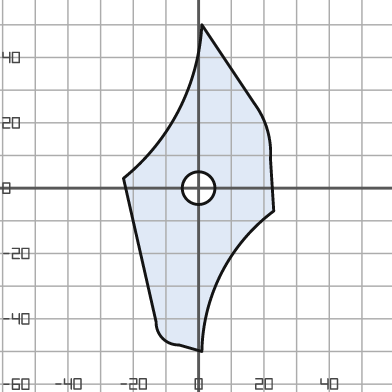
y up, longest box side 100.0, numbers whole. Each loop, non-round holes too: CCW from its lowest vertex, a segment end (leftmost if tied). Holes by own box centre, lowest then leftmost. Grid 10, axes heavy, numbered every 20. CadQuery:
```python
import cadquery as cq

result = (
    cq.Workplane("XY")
    .moveTo(1.0, -50.0)
    .threePointArc((7.0, -26.0), (23.0, -7.0))
    .lineTo(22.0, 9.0)
    .threePointArc((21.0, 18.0), (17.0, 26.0))
    .lineTo(1.0, 50.0)
    .threePointArc((-6.0, 24.0), (-23.0, 3.0))
    .lineTo(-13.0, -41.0)
    .threePointArc((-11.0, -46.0), (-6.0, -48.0))
    .close()
    .moveTo(0.0, 0.0)
    .circle(5.0)
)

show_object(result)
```